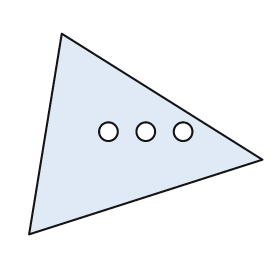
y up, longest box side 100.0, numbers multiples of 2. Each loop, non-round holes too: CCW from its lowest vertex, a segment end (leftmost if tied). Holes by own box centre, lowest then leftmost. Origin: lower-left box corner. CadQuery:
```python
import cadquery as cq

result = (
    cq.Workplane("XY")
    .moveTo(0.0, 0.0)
    .lineTo(100.0, 32.0)
    .lineTo(14.0, 86.0)
    .close()
    .moveTo(34.0, 44.0)
    .circle(4.0)
    .moveTo(50.0, 44.0)
    .circle(4.0)
    .moveTo(66.0, 44.0)
    .circle(4.0)
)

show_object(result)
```